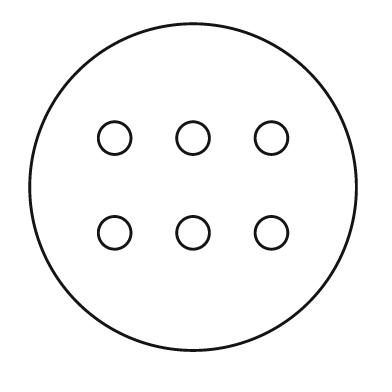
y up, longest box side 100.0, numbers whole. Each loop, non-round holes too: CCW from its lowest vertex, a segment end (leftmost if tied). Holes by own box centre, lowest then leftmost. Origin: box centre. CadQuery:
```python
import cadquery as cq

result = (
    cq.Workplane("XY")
    .moveTo(0.0, 0.0)
    .circle(50.0)
    .moveTo(-24.0, -14.0)
    .circle(5.0)
    .moveTo(0.0, -14.0)
    .circle(5.0)
    .moveTo(24.0, -14.0)
    .circle(5.0)
    .moveTo(-24.0, 15.0)
    .circle(5.0)
    .moveTo(0.0, 15.0)
    .circle(5.0)
    .moveTo(24.0, 15.0)
    .circle(5.0)
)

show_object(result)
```